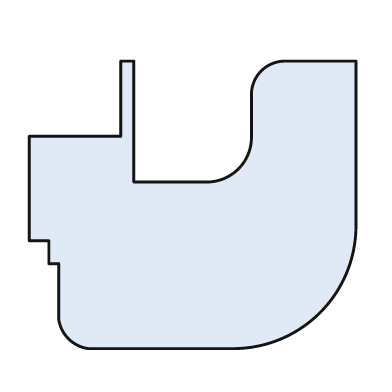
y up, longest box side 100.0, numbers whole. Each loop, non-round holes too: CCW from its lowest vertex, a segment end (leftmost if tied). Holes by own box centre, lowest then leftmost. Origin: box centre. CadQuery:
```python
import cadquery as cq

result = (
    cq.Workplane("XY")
    .moveTo(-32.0, -44.0)
    .lineTo(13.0, -44.0)
    .threePointArc((39.0, -33.0), (50.0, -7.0))
    .lineTo(50.0, 44.0)
    .lineTo(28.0, 44.0)
    .threePointArc((21.0, 41.0), (18.0, 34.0))
    .lineTo(18.0, 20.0)
    .threePointArc((14.0, 11.0), (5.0, 7.0))
    .lineTo(-18.0, 7.0)
    .lineTo(-18.0, 44.0)
    .lineTo(-22.0, 44.0)
    .lineTo(-22.0, 21.0)
    .lineTo(-50.0, 21.0)
    .lineTo(-50.0, -11.0)
    .lineTo(-44.0, -11.0)
    .lineTo(-44.0, -18.0)
    .lineTo(-41.0, -18.0)
    .lineTo(-41.0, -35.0)
    .threePointArc((-38.0, -41.0), (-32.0, -44.0))
    .close()
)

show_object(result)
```